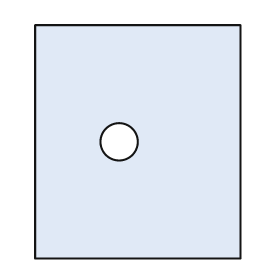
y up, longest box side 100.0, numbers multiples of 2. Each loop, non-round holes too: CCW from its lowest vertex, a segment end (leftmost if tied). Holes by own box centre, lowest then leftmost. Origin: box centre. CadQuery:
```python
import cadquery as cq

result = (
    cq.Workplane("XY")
    .moveTo(-44.0, -50.0)
    .lineTo(44.0, -50.0)
    .lineTo(44.0, 50.0)
    .lineTo(-44.0, 50.0)
    .close()
    .moveTo(-8.0, 0.0)
    .circle(8.0)
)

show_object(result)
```